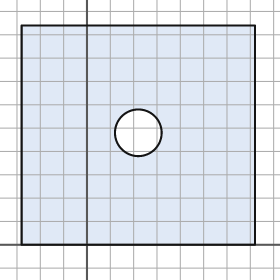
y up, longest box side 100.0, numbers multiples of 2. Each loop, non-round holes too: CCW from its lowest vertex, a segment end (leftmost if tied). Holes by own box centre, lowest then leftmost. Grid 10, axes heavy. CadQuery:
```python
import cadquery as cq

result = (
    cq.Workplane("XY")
    .moveTo(-28.0, 0.0)
    .lineTo(72.0, 0.0)
    .lineTo(72.0, 94.0)
    .lineTo(-28.0, 94.0)
    .close()
    .moveTo(22.0, 48.0)
    .circle(10.0)
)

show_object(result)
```